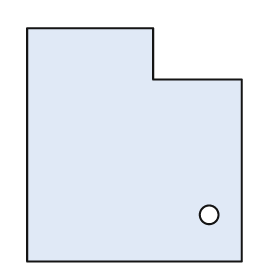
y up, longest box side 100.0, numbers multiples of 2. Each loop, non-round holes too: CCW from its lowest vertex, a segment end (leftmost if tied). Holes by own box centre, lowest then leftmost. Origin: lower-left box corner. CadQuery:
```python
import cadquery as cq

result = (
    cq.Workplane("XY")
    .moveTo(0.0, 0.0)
    .lineTo(92.0, 0.0)
    .lineTo(92.0, 78.0)
    .lineTo(54.0, 78.0)
    .lineTo(54.0, 100.0)
    .lineTo(0.0, 100.0)
    .close()
    .moveTo(78.0, 20.0)
    .circle(4.0)
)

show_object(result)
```